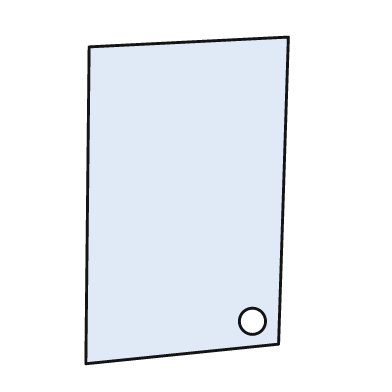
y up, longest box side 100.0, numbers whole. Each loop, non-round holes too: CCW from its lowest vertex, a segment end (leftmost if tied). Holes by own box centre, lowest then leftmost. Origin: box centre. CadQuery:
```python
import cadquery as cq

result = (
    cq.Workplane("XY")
    .moveTo(-31.0, -50.0)
    .lineTo(28.0, -44.0)
    .lineTo(31.0, 50.0)
    .lineTo(-30.0, 47.0)
    .close()
    .moveTo(20.0, -37.0)
    .circle(4.0)
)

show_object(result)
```